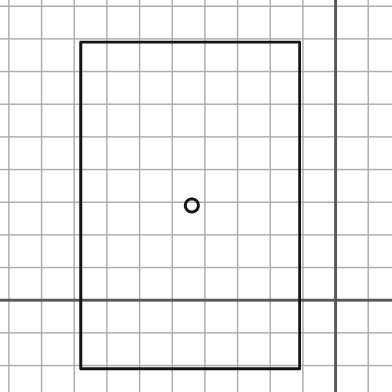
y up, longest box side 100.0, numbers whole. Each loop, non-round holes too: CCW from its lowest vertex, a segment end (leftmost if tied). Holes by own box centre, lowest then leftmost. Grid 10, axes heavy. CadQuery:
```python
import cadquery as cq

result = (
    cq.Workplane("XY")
    .moveTo(-78.0, -21.0)
    .lineTo(-11.0, -21.0)
    .lineTo(-11.0, 79.0)
    .lineTo(-78.0, 79.0)
    .close()
    .moveTo(-44.0, 29.0)
    .circle(2.0)
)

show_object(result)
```